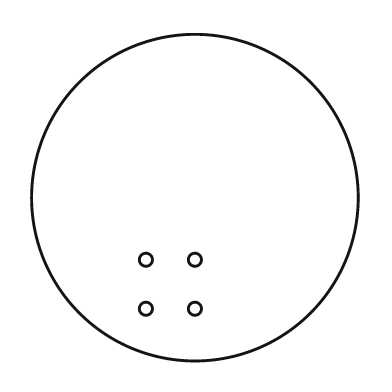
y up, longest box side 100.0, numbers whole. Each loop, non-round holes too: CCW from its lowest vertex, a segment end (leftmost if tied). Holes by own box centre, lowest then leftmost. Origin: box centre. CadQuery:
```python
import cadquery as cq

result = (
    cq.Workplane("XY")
    .moveTo(0.0, 0.0)
    .circle(50.0)
    .moveTo(-15.0, -34.0)
    .circle(2.0)
    .moveTo(0.0, -34.0)
    .circle(2.0)
    .moveTo(-15.0, -19.0)
    .circle(2.0)
    .moveTo(0.0, -19.0)
    .circle(2.0)
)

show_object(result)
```